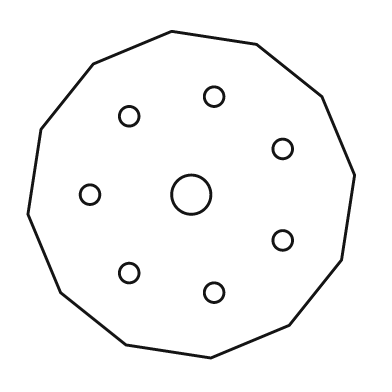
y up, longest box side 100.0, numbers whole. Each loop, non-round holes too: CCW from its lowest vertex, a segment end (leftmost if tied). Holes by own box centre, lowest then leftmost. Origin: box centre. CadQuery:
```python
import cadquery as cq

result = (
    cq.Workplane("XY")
    .moveTo(6.0, -50.0)
    .lineTo(30.0, -40.0)
    .lineTo(46.0, -20.0)
    .lineTo(50.0, 6.0)
    .lineTo(40.0, 30.0)
    .lineTo(20.0, 46.0)
    .lineTo(-6.0, 50.0)
    .lineTo(-30.0, 40.0)
    .lineTo(-46.0, 20.0)
    .lineTo(-50.0, -6.0)
    .lineTo(-40.0, -30.0)
    .lineTo(-20.0, -46.0)
    .close()
    .moveTo(7.0, -30.0)
    .circle(3.0)
    .moveTo(-19.0, -24.0)
    .circle(3.0)
    .moveTo(28.0, -14.0)
    .circle(3.0)
    .moveTo(-31.0, 0.0)
    .circle(3.0)
    .moveTo(0.0, 0.0)
    .circle(6.0)
    .moveTo(28.0, 14.0)
    .circle(3.0)
    .moveTo(-19.0, 24.0)
    .circle(3.0)
    .moveTo(7.0, 30.0)
    .circle(3.0)
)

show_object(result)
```